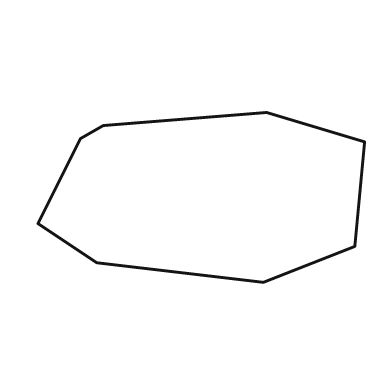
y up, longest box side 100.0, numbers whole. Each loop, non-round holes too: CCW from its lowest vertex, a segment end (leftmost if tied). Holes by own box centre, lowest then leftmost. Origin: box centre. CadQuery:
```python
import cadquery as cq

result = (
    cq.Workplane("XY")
    .moveTo(19.0, -26.0)
    .lineTo(47.0, -15.0)
    .lineTo(50.0, 17.0)
    .lineTo(20.0, 26.0)
    .lineTo(-30.0, 22.0)
    .lineTo(-37.0, 18.0)
    .lineTo(-50.0, -8.0)
    .lineTo(-32.0, -20.0)
    .close()
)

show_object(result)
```